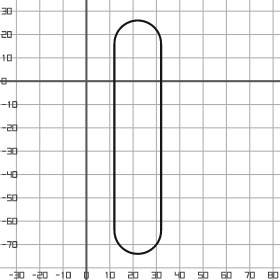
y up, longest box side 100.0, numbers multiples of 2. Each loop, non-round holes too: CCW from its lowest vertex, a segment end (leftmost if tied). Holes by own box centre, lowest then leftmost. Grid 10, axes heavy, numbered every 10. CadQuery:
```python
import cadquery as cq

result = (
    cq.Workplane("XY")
    .moveTo(12.0, -64.0)
    .threePointArc((22.0, -74.0), (32.0, -64.0))
    .lineTo(32.0, 16.0)
    .threePointArc((22.0, 26.0), (12.0, 16.0))
    .close()
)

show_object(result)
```